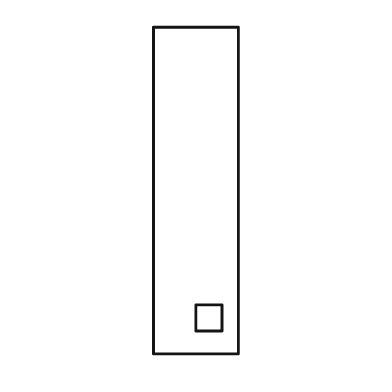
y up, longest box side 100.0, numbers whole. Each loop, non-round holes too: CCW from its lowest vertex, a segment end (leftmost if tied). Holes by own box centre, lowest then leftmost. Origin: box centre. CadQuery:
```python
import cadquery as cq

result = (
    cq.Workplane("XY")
    .moveTo(-13.0, -50.0)
    .lineTo(13.0, -50.0)
    .lineTo(13.0, 50.0)
    .lineTo(-13.0, 50.0)
    .close()
    .moveTo(0.0, -43.0)
    .lineTo(8.0, -43.0)
    .lineTo(8.0, -35.0)
    .lineTo(0.0, -35.0)
    .close()
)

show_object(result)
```